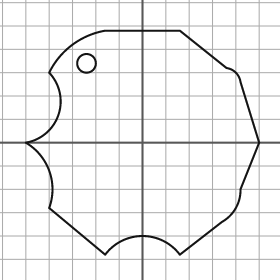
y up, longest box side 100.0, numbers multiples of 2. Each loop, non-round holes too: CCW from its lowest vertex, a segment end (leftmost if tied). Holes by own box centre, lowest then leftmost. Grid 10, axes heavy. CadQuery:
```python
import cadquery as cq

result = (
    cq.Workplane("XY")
    .moveTo(-16.0, -48.0)
    .threePointArc((0.0, -40.0), (16.0, -48.0))
    .lineTo(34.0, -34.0)
    .threePointArc((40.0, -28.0), (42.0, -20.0))
    .lineTo(50.0, 0.0)
    .lineTo(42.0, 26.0)
    .threePointArc((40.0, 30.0), (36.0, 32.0))
    .lineTo(16.0, 48.0)
    .lineTo(-16.0, 48.0)
    .threePointArc((-30.0, 42.0), (-40.0, 30.0))
    .threePointArc((-36.0, 12.0), (-50.0, 0.0))
    .threePointArc((-40.0, -12.0), (-40.0, -28.0))
    .close()
    .moveTo(-24.0, 34.0)
    .circle(4.0)
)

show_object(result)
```